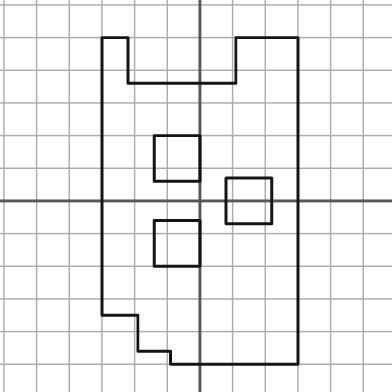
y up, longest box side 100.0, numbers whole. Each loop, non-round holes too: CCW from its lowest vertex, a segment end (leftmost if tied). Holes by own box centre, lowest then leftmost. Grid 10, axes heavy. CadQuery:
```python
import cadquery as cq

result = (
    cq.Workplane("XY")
    .moveTo(-9.0, -50.0)
    .lineTo(30.0, -50.0)
    .lineTo(30.0, 50.0)
    .lineTo(11.0, 50.0)
    .lineTo(11.0, 36.0)
    .lineTo(-22.0, 36.0)
    .lineTo(-22.0, 50.0)
    .lineTo(-30.0, 50.0)
    .lineTo(-30.0, -35.0)
    .lineTo(-19.0, -35.0)
    .lineTo(-19.0, -46.0)
    .lineTo(-9.0, -46.0)
    .close()
    .moveTo(-14.0, -20.0)
    .lineTo(0.0, -20.0)
    .lineTo(0.0, -6.0)
    .lineTo(-14.0, -6.0)
    .close()
    .moveTo(8.0, -7.0)
    .lineTo(22.0, -7.0)
    .lineTo(22.0, 7.0)
    .lineTo(8.0, 7.0)
    .close()
    .moveTo(-14.0, 6.0)
    .lineTo(0.0, 6.0)
    .lineTo(0.0, 20.0)
    .lineTo(-14.0, 20.0)
    .close()
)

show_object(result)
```